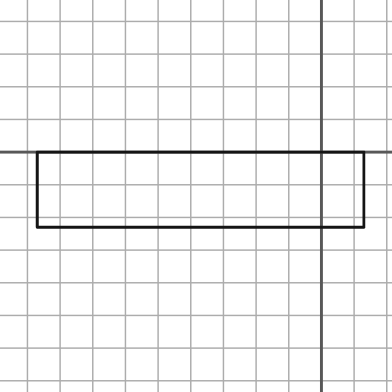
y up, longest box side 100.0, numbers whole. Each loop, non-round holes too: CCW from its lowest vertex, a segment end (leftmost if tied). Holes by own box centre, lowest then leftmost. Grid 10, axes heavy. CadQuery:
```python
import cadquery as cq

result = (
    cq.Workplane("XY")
    .moveTo(-87.0, -23.0)
    .lineTo(13.0, -23.0)
    .lineTo(13.0, 0.0)
    .lineTo(-87.0, 0.0)
    .close()
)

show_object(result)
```